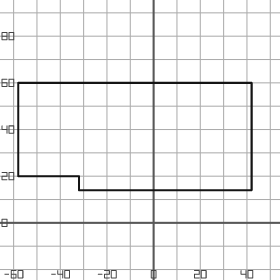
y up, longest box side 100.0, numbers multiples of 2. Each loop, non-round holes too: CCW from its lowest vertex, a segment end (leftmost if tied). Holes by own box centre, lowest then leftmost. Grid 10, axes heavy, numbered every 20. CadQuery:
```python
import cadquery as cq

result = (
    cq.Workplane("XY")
    .moveTo(-32.0, 14.0)
    .lineTo(42.0, 14.0)
    .lineTo(42.0, 60.0)
    .lineTo(-58.0, 60.0)
    .lineTo(-58.0, 20.0)
    .lineTo(-32.0, 20.0)
    .close()
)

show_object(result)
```